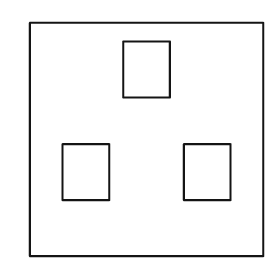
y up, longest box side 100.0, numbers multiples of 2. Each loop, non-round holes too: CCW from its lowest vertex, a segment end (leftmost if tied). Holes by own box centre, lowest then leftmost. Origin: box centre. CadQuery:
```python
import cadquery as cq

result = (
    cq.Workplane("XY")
    .moveTo(-50.0, -50.0)
    .lineTo(50.0, -50.0)
    .lineTo(50.0, 50.0)
    .lineTo(-50.0, 50.0)
    .close()
    .moveTo(-36.0, -26.0)
    .lineTo(-16.0, -26.0)
    .lineTo(-16.0, -2.0)
    .lineTo(-36.0, -2.0)
    .close()
    .moveTo(16.0, -26.0)
    .lineTo(36.0, -26.0)
    .lineTo(36.0, -2.0)
    .lineTo(16.0, -2.0)
    .close()
    .moveTo(-10.0, 18.0)
    .lineTo(10.0, 18.0)
    .lineTo(10.0, 42.0)
    .lineTo(-10.0, 42.0)
    .close()
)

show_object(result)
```